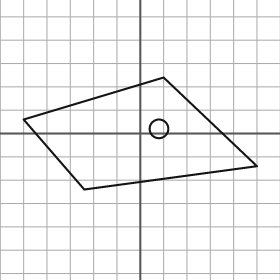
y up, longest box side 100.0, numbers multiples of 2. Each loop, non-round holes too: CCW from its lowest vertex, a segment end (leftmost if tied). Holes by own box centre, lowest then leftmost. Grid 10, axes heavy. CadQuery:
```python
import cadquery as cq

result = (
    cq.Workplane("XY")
    .moveTo(-24.0, -24.0)
    .lineTo(50.0, -14.0)
    .lineTo(10.0, 24.0)
    .lineTo(-50.0, 6.0)
    .close()
    .moveTo(8.0, 2.0)
    .circle(4.0)
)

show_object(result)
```